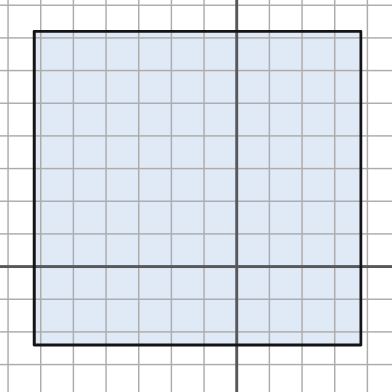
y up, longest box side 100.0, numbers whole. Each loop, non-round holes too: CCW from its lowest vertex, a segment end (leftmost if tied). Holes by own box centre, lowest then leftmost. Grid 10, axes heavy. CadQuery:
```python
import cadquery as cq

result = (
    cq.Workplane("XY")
    .moveTo(-62.0, -24.0)
    .lineTo(38.0, -24.0)
    .lineTo(38.0, 72.0)
    .lineTo(-62.0, 72.0)
    .close()
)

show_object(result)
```